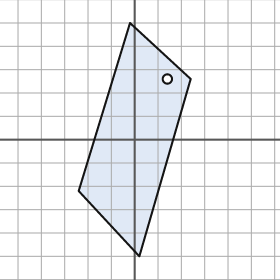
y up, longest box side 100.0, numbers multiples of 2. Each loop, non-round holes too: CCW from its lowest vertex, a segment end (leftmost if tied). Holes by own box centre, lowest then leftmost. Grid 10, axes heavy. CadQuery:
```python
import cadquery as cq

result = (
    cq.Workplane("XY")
    .moveTo(2.0, -50.0)
    .lineTo(24.0, 26.0)
    .lineTo(-2.0, 50.0)
    .lineTo(-24.0, -22.0)
    .close()
    .moveTo(14.0, 26.0)
    .circle(2.0)
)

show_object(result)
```